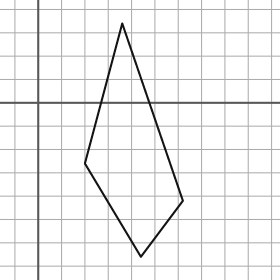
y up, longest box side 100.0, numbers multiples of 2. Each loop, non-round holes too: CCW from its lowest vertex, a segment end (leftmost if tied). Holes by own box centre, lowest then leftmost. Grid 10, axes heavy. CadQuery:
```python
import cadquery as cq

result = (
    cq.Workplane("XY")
    .moveTo(44.0, -66.0)
    .lineTo(62.0, -42.0)
    .lineTo(36.0, 34.0)
    .lineTo(20.0, -26.0)
    .close()
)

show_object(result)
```